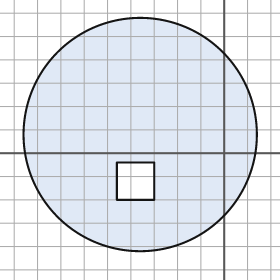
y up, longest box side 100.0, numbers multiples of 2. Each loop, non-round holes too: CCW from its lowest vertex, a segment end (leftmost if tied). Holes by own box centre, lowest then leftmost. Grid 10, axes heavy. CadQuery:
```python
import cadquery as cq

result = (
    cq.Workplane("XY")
    .moveTo(-36.0, 8.0)
    .circle(50.0)
    .moveTo(-46.0, -20.0)
    .lineTo(-30.0, -20.0)
    .lineTo(-30.0, -4.0)
    .lineTo(-46.0, -4.0)
    .close()
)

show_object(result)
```